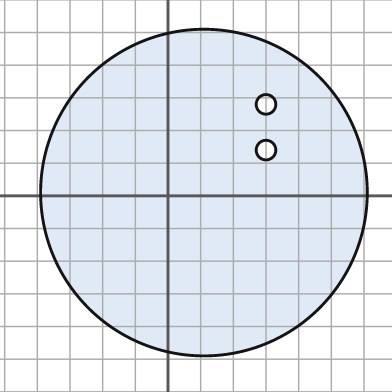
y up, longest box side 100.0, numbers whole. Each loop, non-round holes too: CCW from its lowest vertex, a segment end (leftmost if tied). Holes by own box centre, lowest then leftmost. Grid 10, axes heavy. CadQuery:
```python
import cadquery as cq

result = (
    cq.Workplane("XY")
    .moveTo(11.0, 1.0)
    .circle(50.0)
    .moveTo(30.0, 14.0)
    .circle(3.0)
    .moveTo(30.0, 28.0)
    .circle(3.0)
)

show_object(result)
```